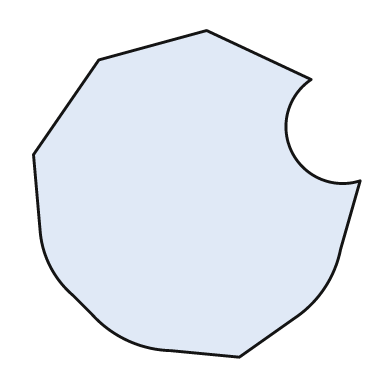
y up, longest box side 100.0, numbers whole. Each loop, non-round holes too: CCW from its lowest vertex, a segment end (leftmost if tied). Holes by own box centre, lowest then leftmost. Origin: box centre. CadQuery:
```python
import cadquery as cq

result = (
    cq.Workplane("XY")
    .moveTo(13.0, -50.0)
    .lineTo(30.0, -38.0)
    .threePointArc((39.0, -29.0), (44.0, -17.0))
    .lineTo(50.0, 4.0)
    .threePointArc((29.0, 13.0), (35.0, 35.0))
    .lineTo(3.0, 50.0)
    .lineTo(-30.0, 41.0)
    .lineTo(-50.0, 12.0)
    .lineTo(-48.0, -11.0)
    .threePointArc((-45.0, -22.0), (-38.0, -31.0))
    .lineTo(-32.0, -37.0)
    .threePointArc((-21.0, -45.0), (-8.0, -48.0))
    .close()
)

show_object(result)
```